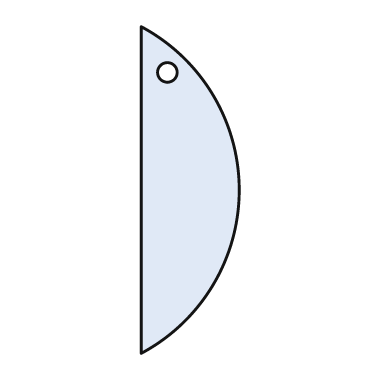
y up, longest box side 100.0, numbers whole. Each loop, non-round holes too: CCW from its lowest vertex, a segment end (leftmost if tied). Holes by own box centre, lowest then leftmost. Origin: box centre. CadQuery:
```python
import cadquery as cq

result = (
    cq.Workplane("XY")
    .moveTo(-15.0, -50.0)
    .threePointArc((15.0, 0.0), (-15.0, 50.0))
    .close()
    .moveTo(-7.0, 36.0)
    .circle(3.0)
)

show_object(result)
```